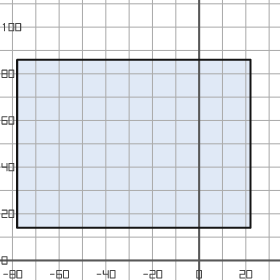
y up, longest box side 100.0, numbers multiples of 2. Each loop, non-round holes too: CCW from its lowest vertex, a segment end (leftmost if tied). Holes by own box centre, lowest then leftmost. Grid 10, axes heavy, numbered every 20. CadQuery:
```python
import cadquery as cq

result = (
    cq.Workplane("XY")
    .moveTo(-78.0, 14.0)
    .lineTo(22.0, 14.0)
    .lineTo(22.0, 86.0)
    .lineTo(-78.0, 86.0)
    .close()
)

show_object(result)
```